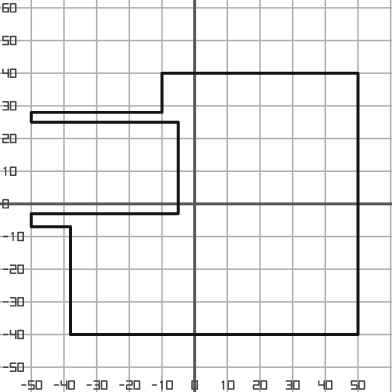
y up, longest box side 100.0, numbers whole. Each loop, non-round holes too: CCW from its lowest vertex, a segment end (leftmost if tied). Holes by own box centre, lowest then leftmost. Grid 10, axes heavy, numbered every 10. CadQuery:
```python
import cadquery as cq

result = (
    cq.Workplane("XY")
    .moveTo(-38.0, -40.0)
    .lineTo(50.0, -40.0)
    .lineTo(50.0, 40.0)
    .lineTo(-10.0, 40.0)
    .lineTo(-10.0, 28.0)
    .lineTo(-50.0, 28.0)
    .lineTo(-50.0, 25.0)
    .lineTo(-5.0, 25.0)
    .lineTo(-5.0, -3.0)
    .lineTo(-50.0, -3.0)
    .lineTo(-50.0, -7.0)
    .lineTo(-38.0, -7.0)
    .close()
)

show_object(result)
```